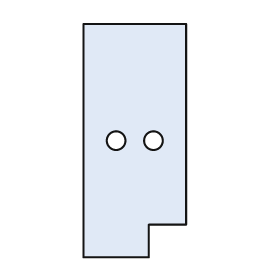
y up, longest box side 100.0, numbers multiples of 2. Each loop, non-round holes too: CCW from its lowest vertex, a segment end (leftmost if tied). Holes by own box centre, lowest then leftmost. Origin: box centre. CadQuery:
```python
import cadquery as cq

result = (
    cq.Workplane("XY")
    .moveTo(-22.0, -50.0)
    .lineTo(6.0, -50.0)
    .lineTo(6.0, -36.0)
    .lineTo(22.0, -36.0)
    .lineTo(22.0, 50.0)
    .lineTo(-22.0, 50.0)
    .close()
    .moveTo(-8.0, 0.0)
    .circle(4.0)
    .moveTo(8.0, 0.0)
    .circle(4.0)
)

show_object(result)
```